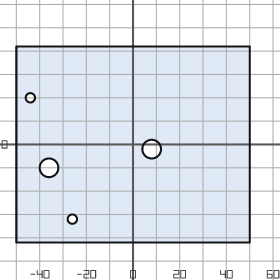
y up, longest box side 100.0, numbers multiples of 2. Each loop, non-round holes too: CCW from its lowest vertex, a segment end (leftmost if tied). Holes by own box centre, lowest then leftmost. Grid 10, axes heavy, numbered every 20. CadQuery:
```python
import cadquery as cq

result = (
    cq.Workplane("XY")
    .moveTo(-50.0, -42.0)
    .lineTo(50.0, -42.0)
    .lineTo(50.0, 42.0)
    .lineTo(-50.0, 42.0)
    .close()
    .moveTo(-26.0, -32.0)
    .circle(2.0)
    .moveTo(-36.0, -10.0)
    .circle(4.0)
    .moveTo(8.0, -2.0)
    .circle(4.0)
    .moveTo(-44.0, 20.0)
    .circle(2.0)
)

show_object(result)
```